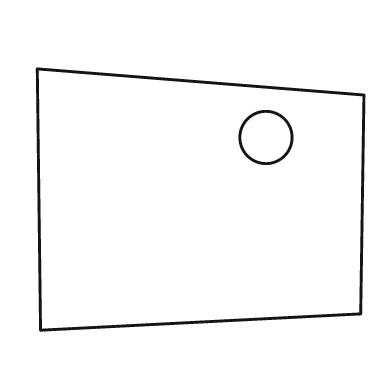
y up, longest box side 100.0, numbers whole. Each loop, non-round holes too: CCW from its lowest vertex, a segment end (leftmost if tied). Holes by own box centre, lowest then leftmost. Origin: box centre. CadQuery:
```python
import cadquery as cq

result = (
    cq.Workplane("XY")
    .moveTo(-49.0, -40.0)
    .lineTo(49.0, -35.0)
    .lineTo(50.0, 32.0)
    .lineTo(-50.0, 40.0)
    .close()
    .moveTo(20.0, 19.0)
    .circle(8.0)
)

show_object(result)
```